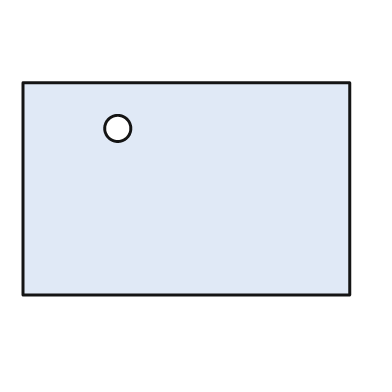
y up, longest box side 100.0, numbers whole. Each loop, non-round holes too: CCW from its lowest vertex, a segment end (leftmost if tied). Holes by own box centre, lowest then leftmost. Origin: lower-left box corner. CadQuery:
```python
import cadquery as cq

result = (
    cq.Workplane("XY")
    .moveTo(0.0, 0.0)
    .lineTo(100.0, 0.0)
    .lineTo(100.0, 65.0)
    .lineTo(0.0, 65.0)
    .close()
    .moveTo(29.0, 51.0)
    .circle(4.0)
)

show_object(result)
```